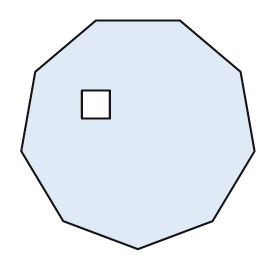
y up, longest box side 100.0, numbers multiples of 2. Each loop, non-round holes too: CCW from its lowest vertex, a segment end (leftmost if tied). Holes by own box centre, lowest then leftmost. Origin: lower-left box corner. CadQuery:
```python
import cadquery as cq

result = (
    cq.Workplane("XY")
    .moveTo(50.0, 0.0)
    .lineTo(82.0, 12.0)
    .lineTo(100.0, 42.0)
    .lineTo(94.0, 76.0)
    .lineTo(68.0, 98.0)
    .lineTo(32.0, 98.0)
    .lineTo(6.0, 76.0)
    .lineTo(0.0, 42.0)
    .lineTo(18.0, 12.0)
    .close()
    .moveTo(26.0, 56.0)
    .lineTo(38.0, 56.0)
    .lineTo(38.0, 68.0)
    .lineTo(26.0, 68.0)
    .close()
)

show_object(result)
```